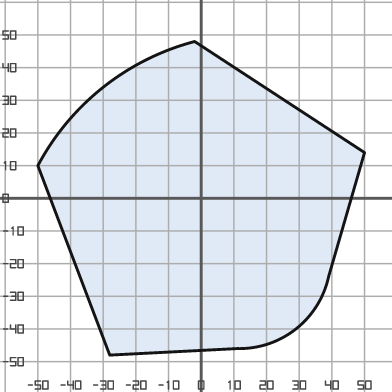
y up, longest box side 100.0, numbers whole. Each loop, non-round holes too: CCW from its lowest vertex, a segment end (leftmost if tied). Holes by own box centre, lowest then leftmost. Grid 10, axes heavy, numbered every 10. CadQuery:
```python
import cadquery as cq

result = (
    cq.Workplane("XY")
    .moveTo(-28.0, -48.0)
    .lineTo(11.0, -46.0)
    .threePointArc((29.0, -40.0), (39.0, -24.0))
    .lineTo(50.0, 14.0)
    .lineTo(-2.0, 48.0)
    .threePointArc((-30.0, 34.0), (-50.0, 10.0))
    .close()
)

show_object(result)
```